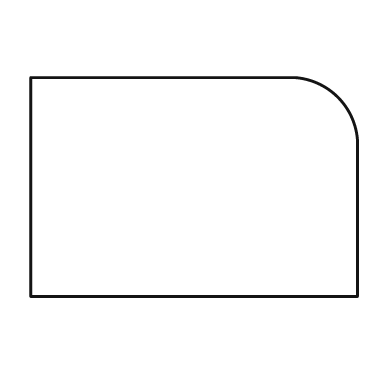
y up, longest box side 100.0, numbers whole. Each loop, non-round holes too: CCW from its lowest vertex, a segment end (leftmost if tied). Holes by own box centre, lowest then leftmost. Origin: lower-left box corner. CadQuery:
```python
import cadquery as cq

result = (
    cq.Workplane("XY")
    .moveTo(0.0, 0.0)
    .lineTo(100.0, 0.0)
    .lineTo(100.0, 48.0)
    .threePointArc((94.0, 61.0), (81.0, 67.0))
    .lineTo(0.0, 67.0)
    .close()
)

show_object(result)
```